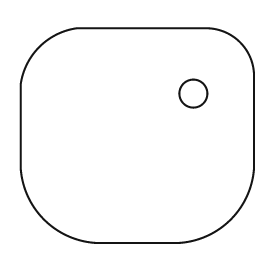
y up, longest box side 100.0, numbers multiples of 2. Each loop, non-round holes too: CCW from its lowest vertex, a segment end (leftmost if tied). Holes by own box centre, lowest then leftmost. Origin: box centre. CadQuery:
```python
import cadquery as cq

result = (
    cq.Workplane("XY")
    .moveTo(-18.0, -46.0)
    .lineTo(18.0, -46.0)
    .threePointArc((40.0, -36.0), (50.0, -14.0))
    .lineTo(50.0, 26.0)
    .threePointArc((44.0, 40.0), (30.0, 46.0))
    .lineTo(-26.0, 46.0)
    .threePointArc((-42.0, 38.0), (-50.0, 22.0))
    .lineTo(-50.0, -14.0)
    .threePointArc((-40.0, -36.0), (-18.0, -46.0))
    .close()
    .moveTo(24.0, 18.0)
    .circle(6.0)
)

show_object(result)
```